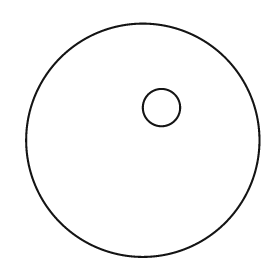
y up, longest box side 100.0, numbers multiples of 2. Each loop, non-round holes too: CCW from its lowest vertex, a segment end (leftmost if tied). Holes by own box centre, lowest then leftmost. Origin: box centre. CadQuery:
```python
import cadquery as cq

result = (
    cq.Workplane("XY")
    .moveTo(0.0, 0.0)
    .circle(50.0)
    .moveTo(8.0, 14.0)
    .circle(8.0)
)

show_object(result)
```